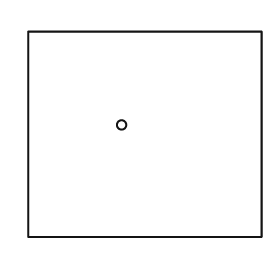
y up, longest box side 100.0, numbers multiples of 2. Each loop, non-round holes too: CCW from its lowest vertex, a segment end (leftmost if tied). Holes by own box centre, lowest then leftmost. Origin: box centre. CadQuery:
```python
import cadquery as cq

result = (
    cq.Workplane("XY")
    .moveTo(-50.0, -44.0)
    .lineTo(50.0, -44.0)
    .lineTo(50.0, 44.0)
    .lineTo(-50.0, 44.0)
    .close()
    .moveTo(-10.0, 4.0)
    .circle(2.0)
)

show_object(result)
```